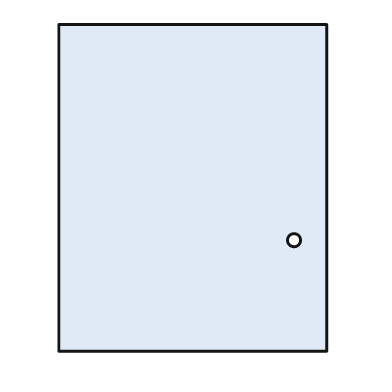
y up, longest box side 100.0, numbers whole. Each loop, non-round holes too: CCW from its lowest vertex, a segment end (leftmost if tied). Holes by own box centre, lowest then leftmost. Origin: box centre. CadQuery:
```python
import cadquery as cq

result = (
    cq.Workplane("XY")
    .moveTo(-41.0, -50.0)
    .lineTo(41.0, -50.0)
    .lineTo(41.0, 50.0)
    .lineTo(-41.0, 50.0)
    .close()
    .moveTo(31.0, -16.0)
    .circle(2.0)
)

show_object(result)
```